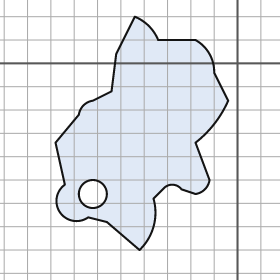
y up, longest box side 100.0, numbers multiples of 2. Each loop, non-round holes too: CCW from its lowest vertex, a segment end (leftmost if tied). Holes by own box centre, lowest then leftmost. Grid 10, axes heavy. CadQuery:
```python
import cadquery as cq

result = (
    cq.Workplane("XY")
    .moveTo(-42.0, -80.0)
    .threePointArc((-36.0, -70.0), (-36.0, -58.0))
    .lineTo(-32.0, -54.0)
    .threePointArc((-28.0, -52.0), (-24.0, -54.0))
    .lineTo(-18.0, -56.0)
    .threePointArc((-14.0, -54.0), (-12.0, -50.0))
    .lineTo(-18.0, -34.0)
    .threePointArc((-10.0, -26.0), (-4.0, -16.0))
    .lineTo(-10.0, -4.0)
    .threePointArc((-12.0, 4.0), (-18.0, 10.0))
    .lineTo(-34.0, 10.0)
    .threePointArc((-38.0, 16.0), (-44.0, 20.0))
    .lineTo(-52.0, 4.0)
    .lineTo(-54.0, -12.0)
    .lineTo(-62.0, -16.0)
    .threePointArc((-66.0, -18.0), (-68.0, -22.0))
    .lineTo(-78.0, -34.0)
    .lineTo(-74.0, -52.0)
    .threePointArc((-76.0, -64.0), (-64.0, -66.0))
    .lineTo(-56.0, -68.0)
    .close()
    .moveTo(-62.0, -56.0)
    .circle(6.0)
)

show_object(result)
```